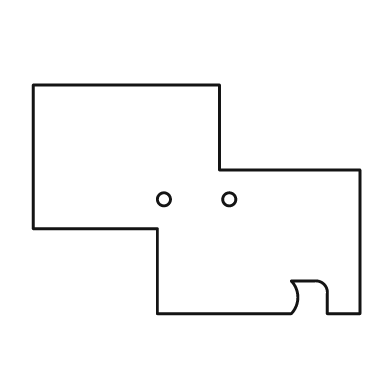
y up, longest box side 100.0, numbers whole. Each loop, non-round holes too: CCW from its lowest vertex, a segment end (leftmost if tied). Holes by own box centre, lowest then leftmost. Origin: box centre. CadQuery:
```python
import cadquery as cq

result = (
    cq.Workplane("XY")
    .moveTo(-12.0, -35.0)
    .lineTo(29.0, -35.0)
    .threePointArc((31.0, -30.0), (29.0, -25.0))
    .lineTo(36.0, -25.0)
    .threePointArc((39.0, -26.0), (40.0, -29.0))
    .lineTo(40.0, -35.0)
    .lineTo(50.0, -35.0)
    .lineTo(50.0, 9.0)
    .lineTo(7.0, 9.0)
    .lineTo(7.0, 35.0)
    .lineTo(-50.0, 35.0)
    .lineTo(-50.0, -9.0)
    .lineTo(-12.0, -9.0)
    .close()
    .moveTo(-10.0, 0.0)
    .circle(2.0)
    .moveTo(10.0, 0.0)
    .circle(2.0)
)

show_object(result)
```